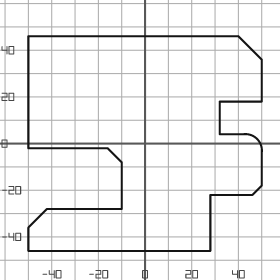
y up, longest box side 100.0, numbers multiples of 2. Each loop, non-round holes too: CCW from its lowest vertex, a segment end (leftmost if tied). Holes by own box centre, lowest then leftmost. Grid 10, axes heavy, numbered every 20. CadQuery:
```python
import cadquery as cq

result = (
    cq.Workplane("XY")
    .moveTo(-50.0, -46.0)
    .lineTo(28.0, -46.0)
    .lineTo(28.0, -22.0)
    .lineTo(46.0, -22.0)
    .lineTo(50.0, -18.0)
    .lineTo(50.0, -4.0)
    .threePointArc((48.0, 2.0), (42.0, 4.0))
    .lineTo(32.0, 4.0)
    .lineTo(32.0, 18.0)
    .lineTo(50.0, 18.0)
    .lineTo(50.0, 36.0)
    .lineTo(40.0, 46.0)
    .lineTo(-50.0, 46.0)
    .lineTo(-50.0, -2.0)
    .lineTo(-16.0, -2.0)
    .lineTo(-10.0, -8.0)
    .lineTo(-10.0, -28.0)
    .lineTo(-42.0, -28.0)
    .lineTo(-50.0, -36.0)
    .close()
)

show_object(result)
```